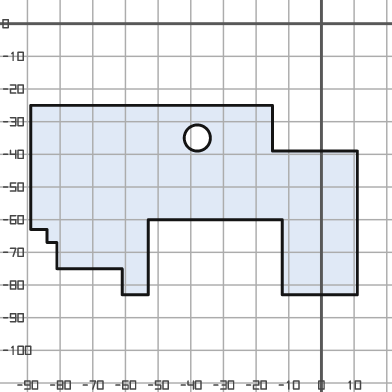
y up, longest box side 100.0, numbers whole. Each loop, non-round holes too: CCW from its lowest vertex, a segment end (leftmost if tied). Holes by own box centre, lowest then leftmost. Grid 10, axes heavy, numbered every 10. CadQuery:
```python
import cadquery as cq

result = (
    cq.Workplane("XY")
    .moveTo(-61.0, -83.0)
    .lineTo(-53.0, -83.0)
    .lineTo(-53.0, -60.0)
    .lineTo(-12.0, -60.0)
    .lineTo(-12.0, -83.0)
    .lineTo(11.0, -83.0)
    .lineTo(11.0, -39.0)
    .lineTo(-15.0, -39.0)
    .lineTo(-15.0, -25.0)
    .lineTo(-89.0, -25.0)
    .lineTo(-89.0, -63.0)
    .lineTo(-84.0, -63.0)
    .lineTo(-84.0, -67.0)
    .lineTo(-81.0, -67.0)
    .lineTo(-81.0, -75.0)
    .lineTo(-61.0, -75.0)
    .close()
    .moveTo(-38.0, -35.0)
    .circle(4.0)
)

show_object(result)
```